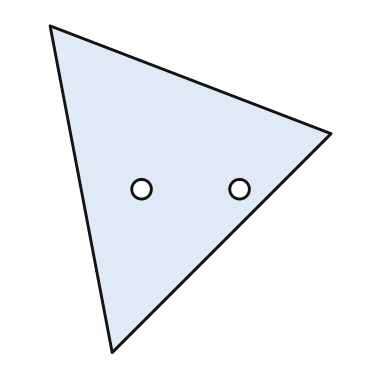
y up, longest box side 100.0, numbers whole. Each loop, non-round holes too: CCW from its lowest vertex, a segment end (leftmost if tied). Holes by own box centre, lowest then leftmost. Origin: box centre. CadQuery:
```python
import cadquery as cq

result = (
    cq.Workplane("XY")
    .moveTo(-24.0, -50.0)
    .lineTo(43.0, 17.0)
    .lineTo(-43.0, 50.0)
    .close()
    .moveTo(-15.0, 0.0)
    .circle(3.0)
    .moveTo(15.0, 0.0)
    .circle(3.0)
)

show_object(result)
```